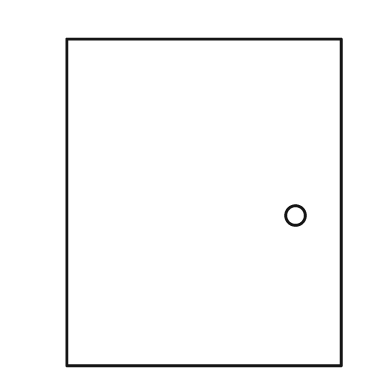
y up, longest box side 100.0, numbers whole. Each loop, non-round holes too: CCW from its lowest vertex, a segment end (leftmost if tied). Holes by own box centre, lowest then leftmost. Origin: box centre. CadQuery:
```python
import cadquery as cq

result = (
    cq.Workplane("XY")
    .moveTo(-42.0, -50.0)
    .lineTo(42.0, -50.0)
    .lineTo(42.0, 50.0)
    .lineTo(-42.0, 50.0)
    .close()
    .moveTo(28.0, -4.0)
    .circle(3.0)
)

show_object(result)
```